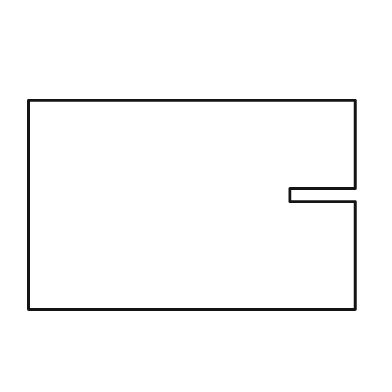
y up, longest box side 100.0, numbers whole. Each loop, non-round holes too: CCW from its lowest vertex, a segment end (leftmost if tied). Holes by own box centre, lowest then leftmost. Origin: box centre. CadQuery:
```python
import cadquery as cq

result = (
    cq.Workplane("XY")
    .moveTo(-50.0, -32.0)
    .lineTo(50.0, -32.0)
    .lineTo(50.0, 1.0)
    .lineTo(30.0, 1.0)
    .lineTo(30.0, 5.0)
    .lineTo(50.0, 5.0)
    .lineTo(50.0, 32.0)
    .lineTo(-50.0, 32.0)
    .close()
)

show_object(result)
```